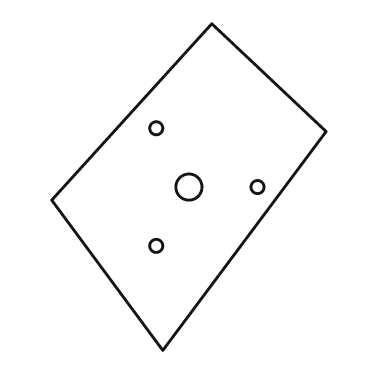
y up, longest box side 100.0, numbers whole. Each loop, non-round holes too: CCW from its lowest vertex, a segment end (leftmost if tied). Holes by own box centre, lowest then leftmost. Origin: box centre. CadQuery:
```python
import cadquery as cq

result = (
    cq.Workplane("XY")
    .moveTo(-8.0, -50.0)
    .lineTo(42.0, 17.0)
    .lineTo(7.0, 50.0)
    .lineTo(-42.0, -4.0)
    .close()
    .moveTo(-10.0, -18.0)
    .circle(2.0)
    .moveTo(0.0, 0.0)
    .circle(4.0)
    .moveTo(21.0, 0.0)
    .circle(2.0)
    .moveTo(-10.0, 18.0)
    .circle(2.0)
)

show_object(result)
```